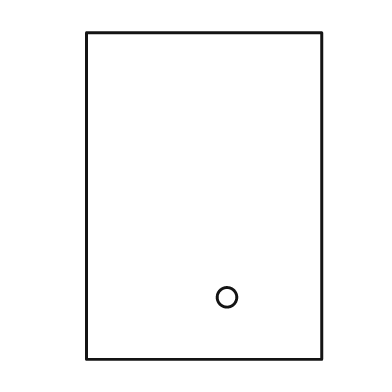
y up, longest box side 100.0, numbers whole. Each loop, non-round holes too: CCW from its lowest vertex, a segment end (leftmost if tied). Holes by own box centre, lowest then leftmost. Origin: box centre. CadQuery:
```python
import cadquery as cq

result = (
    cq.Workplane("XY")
    .moveTo(-36.0, -50.0)
    .lineTo(36.0, -50.0)
    .lineTo(36.0, 50.0)
    .lineTo(-36.0, 50.0)
    .close()
    .moveTo(7.0, -31.0)
    .circle(3.0)
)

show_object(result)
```